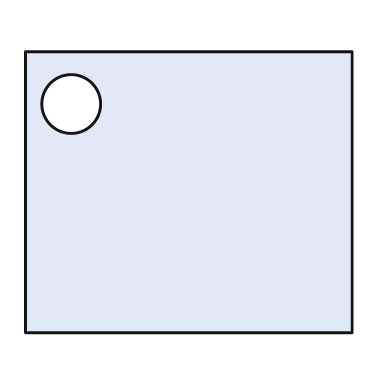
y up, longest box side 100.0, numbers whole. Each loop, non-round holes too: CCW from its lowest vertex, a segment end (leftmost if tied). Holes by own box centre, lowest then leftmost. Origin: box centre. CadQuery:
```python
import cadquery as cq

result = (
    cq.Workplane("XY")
    .moveTo(-50.0, -43.0)
    .lineTo(50.0, -43.0)
    .lineTo(50.0, 43.0)
    .lineTo(-50.0, 43.0)
    .close()
    .moveTo(-36.0, 27.0)
    .circle(9.0)
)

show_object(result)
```